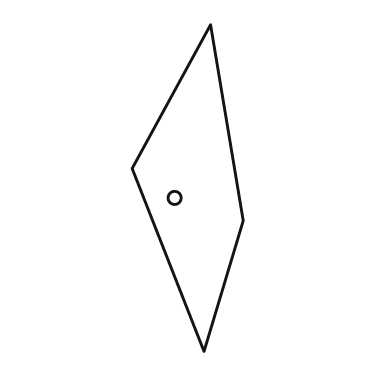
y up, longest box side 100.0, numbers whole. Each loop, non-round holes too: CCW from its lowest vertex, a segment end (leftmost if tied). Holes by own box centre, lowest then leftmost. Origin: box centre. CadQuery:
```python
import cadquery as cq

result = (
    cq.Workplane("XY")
    .moveTo(5.0, -50.0)
    .lineTo(17.0, -10.0)
    .lineTo(7.0, 50.0)
    .lineTo(-17.0, 6.0)
    .close()
    .moveTo(-4.0, -3.0)
    .circle(2.0)
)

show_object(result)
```